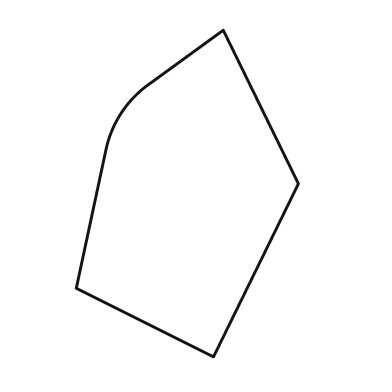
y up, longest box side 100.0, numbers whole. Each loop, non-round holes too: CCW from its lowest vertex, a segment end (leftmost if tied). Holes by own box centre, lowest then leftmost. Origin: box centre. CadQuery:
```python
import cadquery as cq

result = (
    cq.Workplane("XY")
    .moveTo(8.0, -50.0)
    .lineTo(34.0, 3.0)
    .lineTo(11.0, 50.0)
    .lineTo(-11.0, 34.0)
    .threePointArc((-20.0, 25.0), (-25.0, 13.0))
    .lineTo(-34.0, -29.0)
    .close()
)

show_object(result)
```